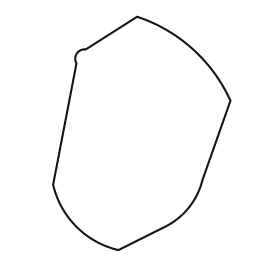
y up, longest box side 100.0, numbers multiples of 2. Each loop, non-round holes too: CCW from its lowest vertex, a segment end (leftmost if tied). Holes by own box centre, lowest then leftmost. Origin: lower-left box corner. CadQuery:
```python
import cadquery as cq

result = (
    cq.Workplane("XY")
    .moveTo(28.0, 0.0)
    .lineTo(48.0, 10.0)
    .threePointArc((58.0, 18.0), (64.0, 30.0))
    .lineTo(76.0, 64.0)
    .threePointArc((60.0, 86.0), (36.0, 100.0))
    .lineTo(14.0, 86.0)
    .threePointArc((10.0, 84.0), (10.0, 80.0))
    .lineTo(0.0, 28.0)
    .threePointArc((10.0, 10.0), (28.0, 0.0))
    .close()
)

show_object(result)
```